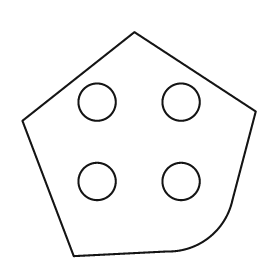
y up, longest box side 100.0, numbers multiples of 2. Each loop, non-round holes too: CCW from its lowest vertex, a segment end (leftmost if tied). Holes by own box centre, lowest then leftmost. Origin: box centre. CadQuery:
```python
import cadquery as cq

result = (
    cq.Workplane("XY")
    .moveTo(-28.0, -48.0)
    .lineTo(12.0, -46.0)
    .threePointArc((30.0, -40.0), (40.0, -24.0))
    .lineTo(50.0, 14.0)
    .lineTo(-2.0, 48.0)
    .lineTo(-50.0, 10.0)
    .close()
    .moveTo(-18.0, -16.0)
    .circle(8.0)
    .moveTo(18.0, -16.0)
    .circle(8.0)
    .moveTo(-18.0, 18.0)
    .circle(8.0)
    .moveTo(18.0, 18.0)
    .circle(8.0)
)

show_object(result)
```